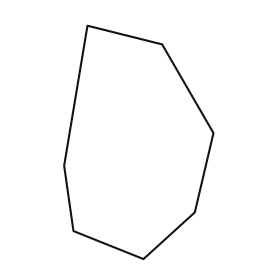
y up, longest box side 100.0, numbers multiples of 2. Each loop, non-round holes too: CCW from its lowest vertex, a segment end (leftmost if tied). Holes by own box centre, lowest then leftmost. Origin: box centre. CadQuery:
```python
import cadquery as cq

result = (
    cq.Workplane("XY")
    .moveTo(2.0, -50.0)
    .lineTo(24.0, -30.0)
    .lineTo(32.0, 4.0)
    .lineTo(10.0, 42.0)
    .lineTo(-22.0, 50.0)
    .lineTo(-32.0, -10.0)
    .lineTo(-28.0, -38.0)
    .close()
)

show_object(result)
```